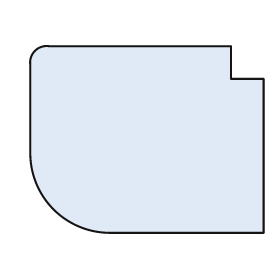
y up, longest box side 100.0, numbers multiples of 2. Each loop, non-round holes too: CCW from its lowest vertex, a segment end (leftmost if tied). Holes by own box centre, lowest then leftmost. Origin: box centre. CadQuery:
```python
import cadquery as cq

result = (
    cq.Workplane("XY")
    .moveTo(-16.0, -40.0)
    .lineTo(50.0, -40.0)
    .lineTo(50.0, 26.0)
    .lineTo(36.0, 26.0)
    .lineTo(36.0, 40.0)
    .lineTo(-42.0, 40.0)
    .threePointArc((-48.0, 38.0), (-50.0, 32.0))
    .lineTo(-50.0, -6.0)
    .threePointArc((-40.0, -30.0), (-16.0, -40.0))
    .close()
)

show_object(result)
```